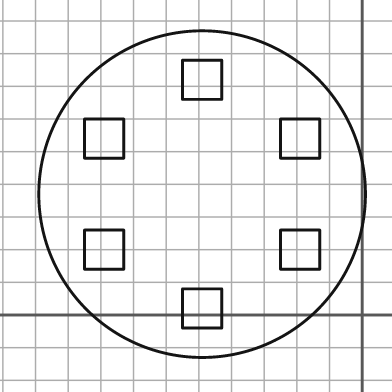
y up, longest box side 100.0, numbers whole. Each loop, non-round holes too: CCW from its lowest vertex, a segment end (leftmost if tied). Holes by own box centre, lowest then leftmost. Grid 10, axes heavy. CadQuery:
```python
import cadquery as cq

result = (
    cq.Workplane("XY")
    .moveTo(-49.0, 37.0)
    .circle(50.0)
    .moveTo(-55.0, -4.0)
    .lineTo(-43.0, -4.0)
    .lineTo(-43.0, 8.0)
    .lineTo(-55.0, 8.0)
    .close()
    .moveTo(-85.0, 14.0)
    .lineTo(-73.0, 14.0)
    .lineTo(-73.0, 26.0)
    .lineTo(-85.0, 26.0)
    .close()
    .moveTo(-25.0, 14.0)
    .lineTo(-13.0, 14.0)
    .lineTo(-13.0, 26.0)
    .lineTo(-25.0, 26.0)
    .close()
    .moveTo(-85.0, 48.0)
    .lineTo(-73.0, 48.0)
    .lineTo(-73.0, 60.0)
    .lineTo(-85.0, 60.0)
    .close()
    .moveTo(-25.0, 48.0)
    .lineTo(-13.0, 48.0)
    .lineTo(-13.0, 60.0)
    .lineTo(-25.0, 60.0)
    .close()
    .moveTo(-55.0, 66.0)
    .lineTo(-43.0, 66.0)
    .lineTo(-43.0, 78.0)
    .lineTo(-55.0, 78.0)
    .close()
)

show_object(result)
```